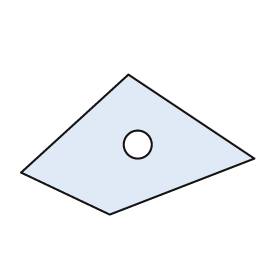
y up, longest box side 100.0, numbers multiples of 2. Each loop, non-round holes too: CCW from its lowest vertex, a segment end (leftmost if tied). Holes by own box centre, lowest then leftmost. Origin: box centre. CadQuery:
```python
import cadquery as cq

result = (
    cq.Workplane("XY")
    .moveTo(-12.0, -30.0)
    .lineTo(50.0, -6.0)
    .lineTo(-4.0, 30.0)
    .lineTo(-50.0, -12.0)
    .close()
    .moveTo(0.0, 0.0)
    .circle(6.0)
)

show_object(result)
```